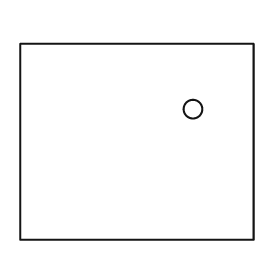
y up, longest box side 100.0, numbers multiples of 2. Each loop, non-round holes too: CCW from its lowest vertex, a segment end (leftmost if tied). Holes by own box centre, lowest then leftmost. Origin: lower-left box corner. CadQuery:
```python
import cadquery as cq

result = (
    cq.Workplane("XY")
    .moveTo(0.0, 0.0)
    .lineTo(100.0, 0.0)
    .lineTo(100.0, 84.0)
    .lineTo(0.0, 84.0)
    .close()
    .moveTo(74.0, 56.0)
    .circle(4.0)
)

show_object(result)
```